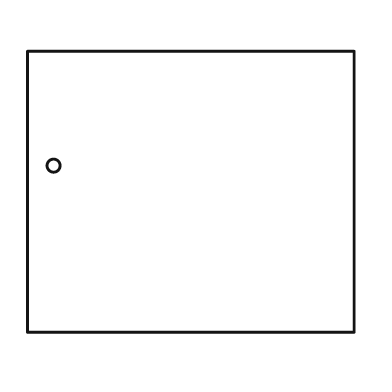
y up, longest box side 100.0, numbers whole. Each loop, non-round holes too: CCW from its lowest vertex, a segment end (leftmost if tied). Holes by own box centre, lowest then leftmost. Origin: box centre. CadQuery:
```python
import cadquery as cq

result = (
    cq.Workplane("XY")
    .moveTo(-50.0, -43.0)
    .lineTo(50.0, -43.0)
    .lineTo(50.0, 43.0)
    .lineTo(-50.0, 43.0)
    .close()
    .moveTo(-42.0, 8.0)
    .circle(2.0)
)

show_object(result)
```